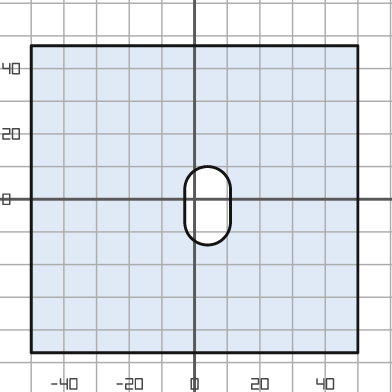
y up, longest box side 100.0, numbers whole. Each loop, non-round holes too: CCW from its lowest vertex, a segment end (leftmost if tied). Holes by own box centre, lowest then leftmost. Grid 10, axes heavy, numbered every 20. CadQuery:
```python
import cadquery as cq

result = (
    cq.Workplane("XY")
    .moveTo(-50.0, -47.0)
    .lineTo(50.0, -47.0)
    .lineTo(50.0, 47.0)
    .lineTo(-50.0, 47.0)
    .close()
    .moveTo(-3.0, -7.0)
    .threePointArc((4.0, -14.0), (11.0, -7.0))
    .lineTo(11.0, 3.0)
    .threePointArc((4.0, 10.0), (-3.0, 3.0))
    .close()
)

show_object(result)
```